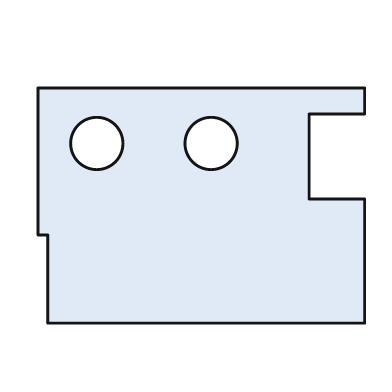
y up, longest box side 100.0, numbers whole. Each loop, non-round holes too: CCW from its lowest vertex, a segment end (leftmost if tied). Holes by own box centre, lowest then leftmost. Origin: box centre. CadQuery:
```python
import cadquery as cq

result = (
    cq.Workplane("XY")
    .moveTo(-47.0, -36.0)
    .lineTo(50.0, -36.0)
    .lineTo(50.0, 2.0)
    .lineTo(33.0, 2.0)
    .lineTo(33.0, 28.0)
    .lineTo(50.0, 28.0)
    .lineTo(50.0, 36.0)
    .lineTo(-50.0, 36.0)
    .lineTo(-50.0, -9.0)
    .lineTo(-47.0, -9.0)
    .close()
    .moveTo(-32.0, 19.0)
    .circle(8.0)
    .moveTo(3.0, 19.0)
    .circle(8.0)
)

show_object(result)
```